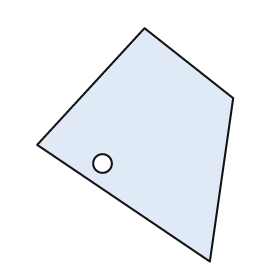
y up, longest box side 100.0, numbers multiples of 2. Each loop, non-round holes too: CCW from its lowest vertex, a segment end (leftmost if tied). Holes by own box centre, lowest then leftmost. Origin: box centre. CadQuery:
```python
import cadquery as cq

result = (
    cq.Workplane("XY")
    .moveTo(32.0, -50.0)
    .lineTo(42.0, 20.0)
    .lineTo(4.0, 50.0)
    .lineTo(-42.0, 0.0)
    .close()
    .moveTo(-14.0, -8.0)
    .circle(4.0)
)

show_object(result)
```